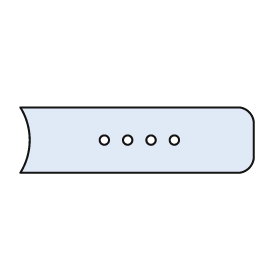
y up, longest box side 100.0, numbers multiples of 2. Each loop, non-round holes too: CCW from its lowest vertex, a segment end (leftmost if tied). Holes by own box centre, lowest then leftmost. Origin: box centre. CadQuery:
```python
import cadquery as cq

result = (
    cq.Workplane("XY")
    .moveTo(-50.0, -14.0)
    .lineTo(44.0, -14.0)
    .threePointArc((48.0, -12.0), (50.0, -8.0))
    .lineTo(50.0, 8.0)
    .threePointArc((48.0, 12.0), (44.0, 14.0))
    .lineTo(-50.0, 14.0)
    .threePointArc((-46.0, 0.0), (-50.0, -14.0))
    .close()
    .moveTo(-14.0, 0.0)
    .circle(2.0)
    .moveTo(-4.0, 0.0)
    .circle(2.0)
    .moveTo(6.0, 0.0)
    .circle(2.0)
    .moveTo(16.0, 0.0)
    .circle(2.0)
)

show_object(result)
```